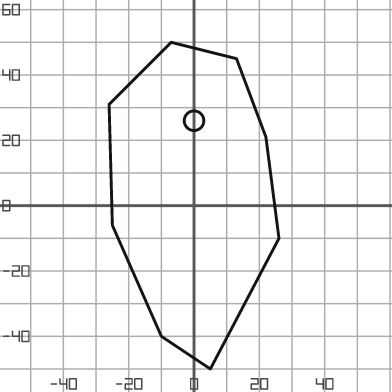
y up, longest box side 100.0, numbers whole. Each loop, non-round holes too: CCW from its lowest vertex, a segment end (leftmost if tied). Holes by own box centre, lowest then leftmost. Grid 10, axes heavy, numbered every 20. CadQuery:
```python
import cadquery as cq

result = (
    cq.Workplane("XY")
    .moveTo(5.0, -50.0)
    .lineTo(26.0, -10.0)
    .lineTo(22.0, 21.0)
    .lineTo(13.0, 45.0)
    .lineTo(-7.0, 50.0)
    .lineTo(-26.0, 31.0)
    .lineTo(-25.0, -6.0)
    .lineTo(-10.0, -40.0)
    .close()
    .moveTo(0.0, 26.0)
    .circle(3.0)
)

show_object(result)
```